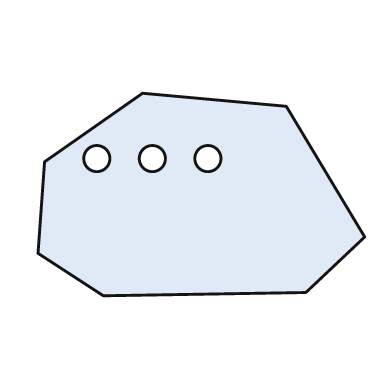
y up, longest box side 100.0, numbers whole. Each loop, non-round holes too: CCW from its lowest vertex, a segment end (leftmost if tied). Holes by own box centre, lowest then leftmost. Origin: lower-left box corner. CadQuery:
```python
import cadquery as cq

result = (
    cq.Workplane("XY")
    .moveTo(20.0, 0.0)
    .lineTo(82.0, 1.0)
    .lineTo(100.0, 18.0)
    .lineTo(76.0, 58.0)
    .lineTo(32.0, 62.0)
    .lineTo(2.0, 41.0)
    .lineTo(0.0, 13.0)
    .close()
    .moveTo(18.0, 42.0)
    .circle(4.0)
    .moveTo(35.0, 42.0)
    .circle(4.0)
    .moveTo(52.0, 42.0)
    .circle(4.0)
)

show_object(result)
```